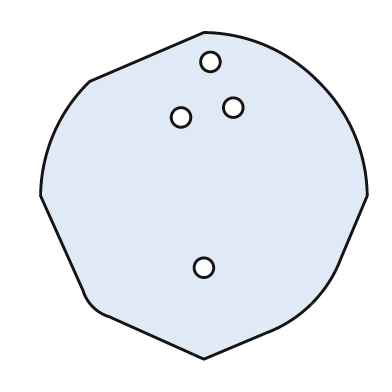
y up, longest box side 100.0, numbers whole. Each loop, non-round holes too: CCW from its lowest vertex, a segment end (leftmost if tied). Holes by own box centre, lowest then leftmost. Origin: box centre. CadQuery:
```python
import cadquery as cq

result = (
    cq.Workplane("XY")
    .moveTo(0.0, -50.0)
    .lineTo(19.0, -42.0)
    .threePointArc((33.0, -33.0), (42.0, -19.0))
    .lineTo(50.0, 0.0)
    .threePointArc((46.0, 19.0), (35.0, 35.0))
    .threePointArc((19.0, 46.0), (0.0, 50.0))
    .lineTo(-35.0, 35.0)
    .threePointArc((-46.0, 19.0), (-50.0, 0.0))
    .lineTo(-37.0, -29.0)
    .threePointArc((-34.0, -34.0), (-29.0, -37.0))
    .close()
    .moveTo(0.0, -22.0)
    .circle(3.0)
    .moveTo(-7.0, 24.0)
    .circle(3.0)
    .moveTo(9.0, 27.0)
    .circle(3.0)
    .moveTo(2.0, 41.0)
    .circle(3.0)
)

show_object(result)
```